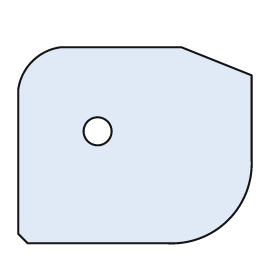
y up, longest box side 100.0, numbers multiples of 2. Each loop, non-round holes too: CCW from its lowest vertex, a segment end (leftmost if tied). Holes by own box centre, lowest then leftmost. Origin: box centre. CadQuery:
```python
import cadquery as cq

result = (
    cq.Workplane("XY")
    .moveTo(-46.0, -42.0)
    .lineTo(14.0, -42.0)
    .threePointArc((40.0, -32.0), (50.0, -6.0))
    .lineTo(50.0, 30.0)
    .lineTo(20.0, 42.0)
    .lineTo(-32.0, 42.0)
    .threePointArc((-44.0, 36.0), (-50.0, 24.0))
    .lineTo(-50.0, -38.0)
    .close()
    .moveTo(-16.0, 6.0)
    .circle(6.0)
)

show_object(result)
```